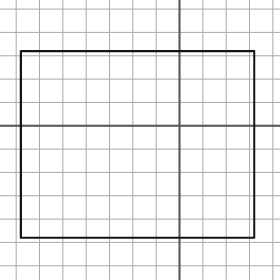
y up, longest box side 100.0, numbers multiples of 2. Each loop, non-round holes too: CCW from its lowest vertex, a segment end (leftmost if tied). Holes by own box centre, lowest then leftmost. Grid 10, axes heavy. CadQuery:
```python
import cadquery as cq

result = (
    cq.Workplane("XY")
    .moveTo(-68.0, -48.0)
    .lineTo(32.0, -48.0)
    .lineTo(32.0, 32.0)
    .lineTo(-68.0, 32.0)
    .close()
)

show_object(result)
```